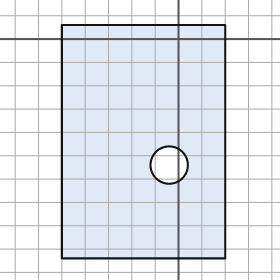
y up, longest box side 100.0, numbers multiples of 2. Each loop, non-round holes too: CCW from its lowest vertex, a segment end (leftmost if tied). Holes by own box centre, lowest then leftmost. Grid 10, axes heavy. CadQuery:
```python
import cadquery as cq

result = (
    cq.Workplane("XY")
    .moveTo(-50.0, -94.0)
    .lineTo(20.0, -94.0)
    .lineTo(20.0, 6.0)
    .lineTo(-50.0, 6.0)
    .close()
    .moveTo(-4.0, -54.0)
    .circle(8.0)
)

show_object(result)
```